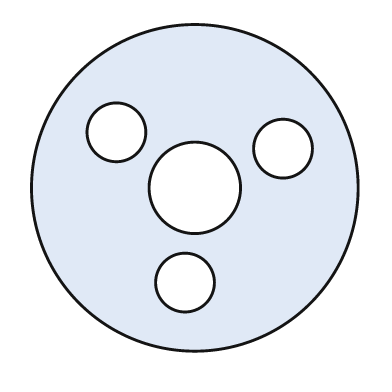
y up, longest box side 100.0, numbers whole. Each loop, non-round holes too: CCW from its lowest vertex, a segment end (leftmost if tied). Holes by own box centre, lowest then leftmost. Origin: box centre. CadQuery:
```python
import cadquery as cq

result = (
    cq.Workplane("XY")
    .moveTo(0.0, 0.0)
    .circle(50.0)
    .moveTo(-3.0, -29.0)
    .circle(9.0)
    .moveTo(0.0, 0.0)
    .circle(14.0)
    .moveTo(27.0, 12.0)
    .circle(9.0)
    .moveTo(-24.0, 17.0)
    .circle(9.0)
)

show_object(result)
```